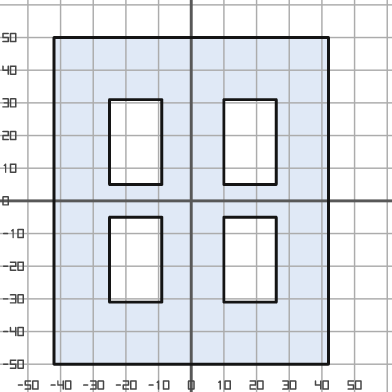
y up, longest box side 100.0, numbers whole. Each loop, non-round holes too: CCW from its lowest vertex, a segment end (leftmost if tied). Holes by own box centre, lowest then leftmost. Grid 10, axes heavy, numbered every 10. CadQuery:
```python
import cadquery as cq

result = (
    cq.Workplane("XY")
    .moveTo(-42.0, -50.0)
    .lineTo(42.0, -50.0)
    .lineTo(42.0, 50.0)
    .lineTo(-42.0, 50.0)
    .close()
    .moveTo(-25.0, -31.0)
    .lineTo(-9.0, -31.0)
    .lineTo(-9.0, -5.0)
    .lineTo(-25.0, -5.0)
    .close()
    .moveTo(10.0, -31.0)
    .lineTo(26.0, -31.0)
    .lineTo(26.0, -5.0)
    .lineTo(10.0, -5.0)
    .close()
    .moveTo(-25.0, 5.0)
    .lineTo(-9.0, 5.0)
    .lineTo(-9.0, 31.0)
    .lineTo(-25.0, 31.0)
    .close()
    .moveTo(10.0, 5.0)
    .lineTo(26.0, 5.0)
    .lineTo(26.0, 31.0)
    .lineTo(10.0, 31.0)
    .close()
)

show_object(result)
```